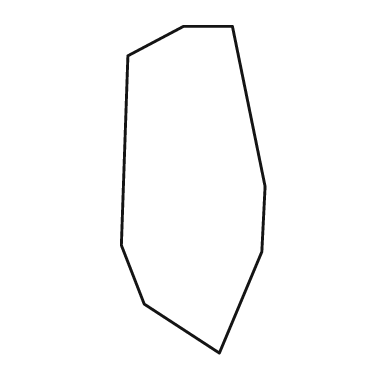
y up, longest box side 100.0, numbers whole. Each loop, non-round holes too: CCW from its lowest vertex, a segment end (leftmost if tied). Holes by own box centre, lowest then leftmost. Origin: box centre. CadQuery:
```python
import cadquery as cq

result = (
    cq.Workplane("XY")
    .moveTo(8.0, -50.0)
    .lineTo(21.0, -19.0)
    .lineTo(22.0, 1.0)
    .lineTo(12.0, 50.0)
    .lineTo(-3.0, 50.0)
    .lineTo(-20.0, 41.0)
    .lineTo(-22.0, -17.0)
    .lineTo(-15.0, -35.0)
    .close()
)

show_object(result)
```